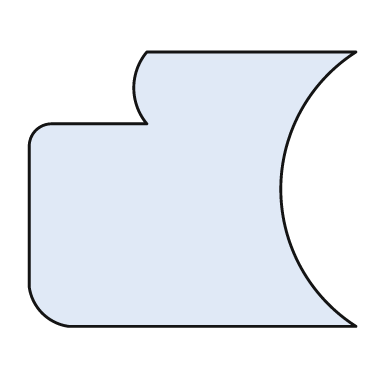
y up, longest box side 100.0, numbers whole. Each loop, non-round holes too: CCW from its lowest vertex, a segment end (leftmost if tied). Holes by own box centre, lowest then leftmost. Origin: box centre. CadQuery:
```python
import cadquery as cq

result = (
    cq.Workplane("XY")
    .moveTo(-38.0, -42.0)
    .lineTo(50.0, -42.0)
    .threePointArc((27.0, 0.0), (50.0, 42.0))
    .lineTo(-14.0, 42.0)
    .threePointArc((-18.0, 31.0), (-14.0, 20.0))
    .lineTo(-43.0, 20.0)
    .threePointArc((-48.0, 18.0), (-50.0, 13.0))
    .lineTo(-50.0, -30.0)
    .threePointArc((-46.0, -38.0), (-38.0, -42.0))
    .close()
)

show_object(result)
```